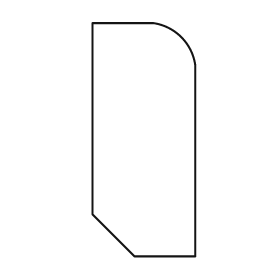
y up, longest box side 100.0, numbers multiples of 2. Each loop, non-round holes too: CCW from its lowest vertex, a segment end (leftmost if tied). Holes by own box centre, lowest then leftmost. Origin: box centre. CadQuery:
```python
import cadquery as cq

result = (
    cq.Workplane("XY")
    .moveTo(-4.0, -50.0)
    .lineTo(22.0, -50.0)
    .lineTo(22.0, 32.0)
    .threePointArc((16.0, 44.0), (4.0, 50.0))
    .lineTo(-22.0, 50.0)
    .lineTo(-22.0, -32.0)
    .close()
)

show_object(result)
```